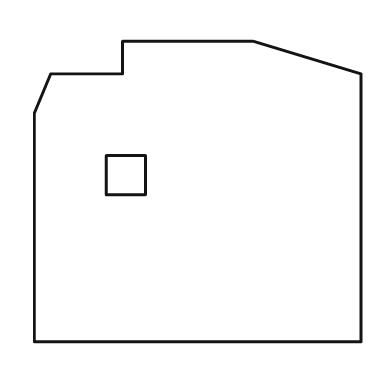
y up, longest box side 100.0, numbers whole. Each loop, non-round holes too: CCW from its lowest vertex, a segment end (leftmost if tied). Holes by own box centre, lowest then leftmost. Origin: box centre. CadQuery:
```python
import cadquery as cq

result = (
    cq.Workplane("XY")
    .moveTo(-50.0, -46.0)
    .lineTo(50.0, -46.0)
    .lineTo(50.0, 36.0)
    .lineTo(17.0, 46.0)
    .lineTo(-23.0, 46.0)
    .lineTo(-23.0, 36.0)
    .lineTo(-45.0, 36.0)
    .lineTo(-50.0, 24.0)
    .close()
    .moveTo(-28.0, -1.0)
    .lineTo(-16.0, -1.0)
    .lineTo(-16.0, 11.0)
    .lineTo(-28.0, 11.0)
    .close()
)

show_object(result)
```